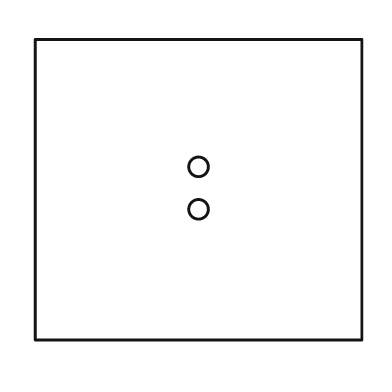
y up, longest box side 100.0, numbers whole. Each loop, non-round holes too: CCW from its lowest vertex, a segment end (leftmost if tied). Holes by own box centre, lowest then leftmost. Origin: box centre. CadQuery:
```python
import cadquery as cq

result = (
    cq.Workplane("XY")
    .moveTo(-50.0, -46.0)
    .lineTo(50.0, -46.0)
    .lineTo(50.0, 46.0)
    .lineTo(-50.0, 46.0)
    .close()
    .moveTo(0.0, -6.0)
    .circle(3.0)
    .moveTo(0.0, 7.0)
    .circle(3.0)
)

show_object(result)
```